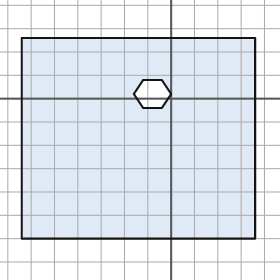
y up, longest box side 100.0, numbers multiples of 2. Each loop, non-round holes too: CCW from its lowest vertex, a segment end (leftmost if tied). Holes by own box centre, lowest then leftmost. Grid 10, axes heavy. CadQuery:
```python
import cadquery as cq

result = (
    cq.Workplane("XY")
    .moveTo(-64.0, -60.0)
    .lineTo(36.0, -60.0)
    .lineTo(36.0, 26.0)
    .lineTo(-64.0, 26.0)
    .close()
    .moveTo(-12.0, -4.0)
    .lineTo(-4.0, -4.0)
    .lineTo(0.0, 2.0)
    .lineTo(-4.0, 8.0)
    .lineTo(-12.0, 8.0)
    .lineTo(-16.0, 2.0)
    .close()
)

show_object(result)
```